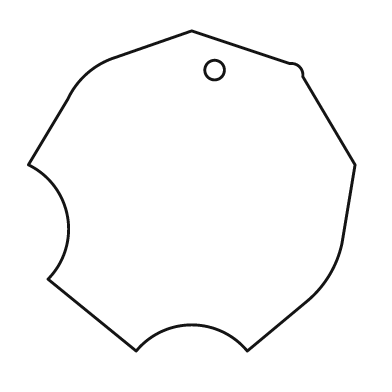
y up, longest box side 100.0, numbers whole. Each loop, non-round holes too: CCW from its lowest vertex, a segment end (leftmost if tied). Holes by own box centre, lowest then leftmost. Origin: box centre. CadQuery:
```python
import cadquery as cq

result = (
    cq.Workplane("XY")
    .moveTo(-17.0, -49.0)
    .threePointArc((0.0, -41.0), (17.0, -49.0))
    .lineTo(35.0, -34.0)
    .threePointArc((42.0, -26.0), (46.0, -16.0))
    .lineTo(50.0, 8.0)
    .lineTo(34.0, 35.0)
    .threePointArc((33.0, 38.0), (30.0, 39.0))
    .lineTo(0.0, 49.0)
    .lineTo(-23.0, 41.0)
    .threePointArc((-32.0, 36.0), (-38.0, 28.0))
    .lineTo(-50.0, 8.0)
    .threePointArc((-38.0, -8.0), (-44.0, -27.0))
    .close()
    .moveTo(7.0, 37.0)
    .circle(3.0)
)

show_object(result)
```